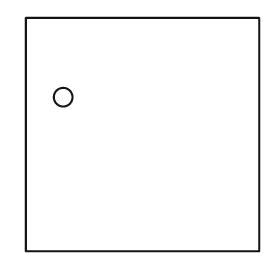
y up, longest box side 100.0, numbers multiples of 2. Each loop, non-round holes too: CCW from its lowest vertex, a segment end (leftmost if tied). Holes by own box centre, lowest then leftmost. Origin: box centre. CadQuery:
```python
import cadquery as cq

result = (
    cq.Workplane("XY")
    .moveTo(-50.0, -50.0)
    .lineTo(50.0, -50.0)
    .lineTo(50.0, 50.0)
    .lineTo(-50.0, 50.0)
    .close()
    .moveTo(-34.0, 16.0)
    .circle(4.0)
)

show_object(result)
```